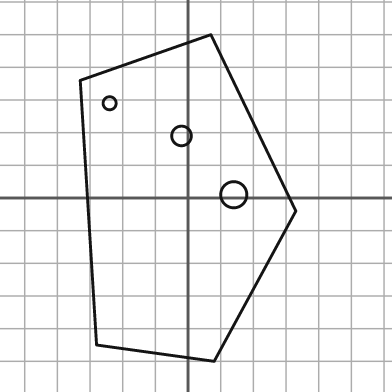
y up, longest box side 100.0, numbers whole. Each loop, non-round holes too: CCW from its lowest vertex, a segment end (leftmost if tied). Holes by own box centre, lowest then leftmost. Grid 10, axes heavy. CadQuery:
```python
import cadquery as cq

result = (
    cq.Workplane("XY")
    .moveTo(8.0, -50.0)
    .lineTo(33.0, -4.0)
    .lineTo(7.0, 50.0)
    .lineTo(-33.0, 36.0)
    .lineTo(-28.0, -45.0)
    .close()
    .moveTo(14.0, 1.0)
    .circle(4.0)
    .moveTo(-2.0, 19.0)
    .circle(3.0)
    .moveTo(-24.0, 29.0)
    .circle(2.0)
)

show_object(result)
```